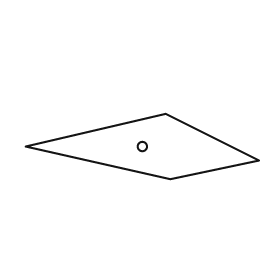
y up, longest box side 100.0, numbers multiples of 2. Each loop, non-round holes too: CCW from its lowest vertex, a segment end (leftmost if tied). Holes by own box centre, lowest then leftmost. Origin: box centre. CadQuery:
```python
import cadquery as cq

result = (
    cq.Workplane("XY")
    .moveTo(12.0, -14.0)
    .lineTo(50.0, -6.0)
    .lineTo(10.0, 14.0)
    .lineTo(-50.0, 0.0)
    .close()
    .moveTo(0.0, 0.0)
    .circle(2.0)
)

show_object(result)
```